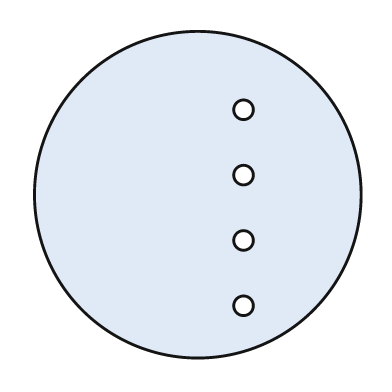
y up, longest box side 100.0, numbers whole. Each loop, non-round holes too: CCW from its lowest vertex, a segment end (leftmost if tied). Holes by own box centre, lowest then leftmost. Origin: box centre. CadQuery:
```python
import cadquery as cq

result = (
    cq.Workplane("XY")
    .moveTo(0.0, 0.0)
    .circle(50.0)
    .moveTo(14.0, -34.0)
    .circle(3.0)
    .moveTo(14.0, -14.0)
    .circle(3.0)
    .moveTo(14.0, 6.0)
    .circle(3.0)
    .moveTo(14.0, 26.0)
    .circle(3.0)
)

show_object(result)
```